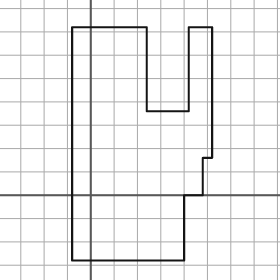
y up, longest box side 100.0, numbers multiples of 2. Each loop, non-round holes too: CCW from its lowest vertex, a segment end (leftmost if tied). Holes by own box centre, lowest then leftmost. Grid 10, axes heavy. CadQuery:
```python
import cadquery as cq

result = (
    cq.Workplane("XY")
    .moveTo(-8.0, -28.0)
    .lineTo(40.0, -28.0)
    .lineTo(40.0, 0.0)
    .lineTo(48.0, 0.0)
    .lineTo(48.0, 16.0)
    .lineTo(52.0, 16.0)
    .lineTo(52.0, 72.0)
    .lineTo(42.0, 72.0)
    .lineTo(42.0, 36.0)
    .lineTo(24.0, 36.0)
    .lineTo(24.0, 72.0)
    .lineTo(-8.0, 72.0)
    .close()
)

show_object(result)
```